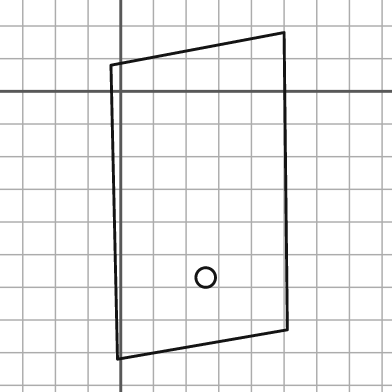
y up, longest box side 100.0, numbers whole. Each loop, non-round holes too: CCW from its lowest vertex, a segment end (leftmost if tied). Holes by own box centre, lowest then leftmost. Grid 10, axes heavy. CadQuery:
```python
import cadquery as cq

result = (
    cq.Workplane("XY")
    .moveTo(-1.0, -82.0)
    .lineTo(51.0, -73.0)
    .lineTo(50.0, 18.0)
    .lineTo(-3.0, 8.0)
    .close()
    .moveTo(26.0, -57.0)
    .circle(3.0)
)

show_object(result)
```